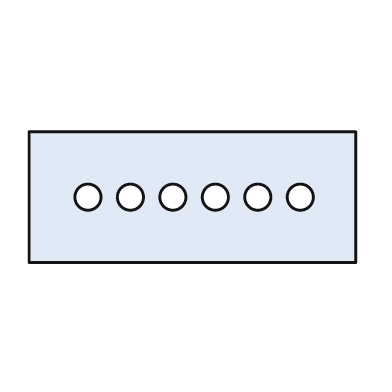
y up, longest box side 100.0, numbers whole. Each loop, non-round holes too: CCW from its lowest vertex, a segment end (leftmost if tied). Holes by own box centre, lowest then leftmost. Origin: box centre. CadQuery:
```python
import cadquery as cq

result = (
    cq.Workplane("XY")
    .moveTo(-50.0, -20.0)
    .lineTo(50.0, -20.0)
    .lineTo(50.0, 20.0)
    .lineTo(-50.0, 20.0)
    .close()
    .moveTo(-32.0, 0.0)
    .circle(4.0)
    .moveTo(-19.0, 0.0)
    .circle(4.0)
    .moveTo(-6.0, 0.0)
    .circle(4.0)
    .moveTo(7.0, 0.0)
    .circle(4.0)
    .moveTo(20.0, 0.0)
    .circle(4.0)
    .moveTo(33.0, 0.0)
    .circle(4.0)
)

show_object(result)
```